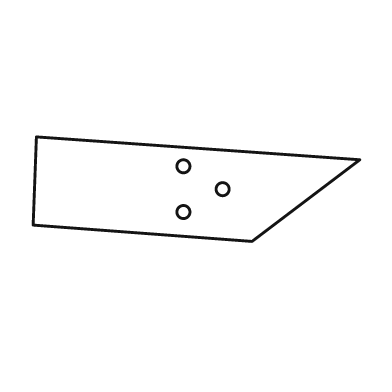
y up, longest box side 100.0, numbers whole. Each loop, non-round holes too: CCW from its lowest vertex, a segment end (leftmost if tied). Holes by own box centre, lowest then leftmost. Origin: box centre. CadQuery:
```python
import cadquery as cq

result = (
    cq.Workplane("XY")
    .moveTo(17.0, -16.0)
    .lineTo(50.0, 9.0)
    .lineTo(-49.0, 16.0)
    .lineTo(-50.0, -11.0)
    .close()
    .moveTo(-4.0, -7.0)
    .circle(2.0)
    .moveTo(8.0, 0.0)
    .circle(2.0)
    .moveTo(-4.0, 7.0)
    .circle(2.0)
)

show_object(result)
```